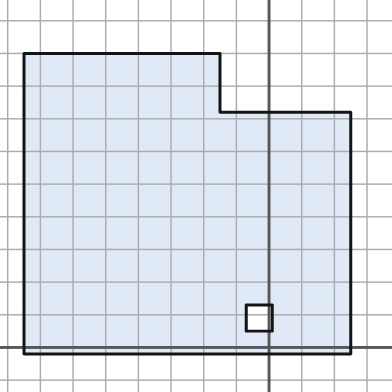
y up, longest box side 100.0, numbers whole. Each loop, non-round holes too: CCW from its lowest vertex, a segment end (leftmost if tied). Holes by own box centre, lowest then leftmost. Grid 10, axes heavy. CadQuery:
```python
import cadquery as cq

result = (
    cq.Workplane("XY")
    .moveTo(-75.0, -2.0)
    .lineTo(25.0, -2.0)
    .lineTo(25.0, 72.0)
    .lineTo(-15.0, 72.0)
    .lineTo(-15.0, 90.0)
    .lineTo(-75.0, 90.0)
    .close()
    .moveTo(-7.0, 5.0)
    .lineTo(1.0, 5.0)
    .lineTo(1.0, 13.0)
    .lineTo(-7.0, 13.0)
    .close()
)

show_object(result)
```